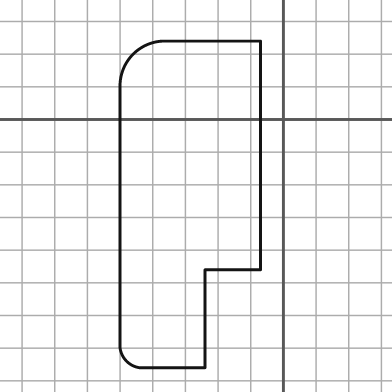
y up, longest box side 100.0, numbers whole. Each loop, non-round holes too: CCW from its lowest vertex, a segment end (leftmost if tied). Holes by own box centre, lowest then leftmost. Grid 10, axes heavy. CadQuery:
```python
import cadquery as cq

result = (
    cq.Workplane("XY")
    .moveTo(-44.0, -76.0)
    .lineTo(-24.0, -76.0)
    .lineTo(-24.0, -46.0)
    .lineTo(-7.0, -46.0)
    .lineTo(-7.0, 24.0)
    .lineTo(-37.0, 24.0)
    .threePointArc((-46.0, 20.0), (-50.0, 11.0))
    .lineTo(-50.0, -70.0)
    .threePointArc((-48.0, -74.0), (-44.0, -76.0))
    .close()
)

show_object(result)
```